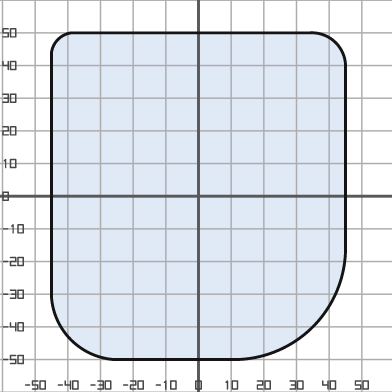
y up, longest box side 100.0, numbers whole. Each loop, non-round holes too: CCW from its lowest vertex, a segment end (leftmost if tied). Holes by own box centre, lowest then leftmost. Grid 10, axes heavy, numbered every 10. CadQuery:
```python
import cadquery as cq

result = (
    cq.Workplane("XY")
    .moveTo(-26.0, -50.0)
    .lineTo(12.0, -50.0)
    .threePointArc((35.0, -40.0), (45.0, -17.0))
    .lineTo(45.0, 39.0)
    .threePointArc((42.0, 47.0), (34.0, 50.0))
    .lineTo(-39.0, 50.0)
    .threePointArc((-43.0, 48.0), (-45.0, 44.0))
    .lineTo(-45.0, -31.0)
    .threePointArc((-39.0, -44.0), (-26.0, -50.0))
    .close()
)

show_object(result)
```